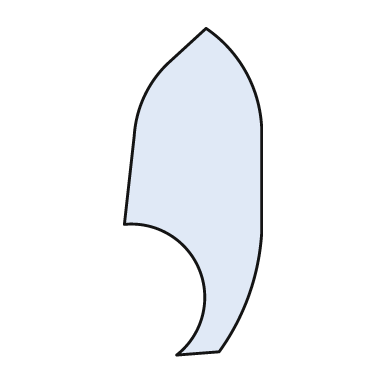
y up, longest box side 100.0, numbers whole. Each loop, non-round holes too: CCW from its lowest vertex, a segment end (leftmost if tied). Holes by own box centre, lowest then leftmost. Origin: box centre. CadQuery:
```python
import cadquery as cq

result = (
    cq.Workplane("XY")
    .moveTo(-5.0, -50.0)
    .lineTo(8.0, -49.0)
    .threePointArc((17.0, -32.0), (21.0, -13.0))
    .lineTo(21.0, 20.0)
    .threePointArc((16.0, 37.0), (4.0, 50.0))
    .lineTo(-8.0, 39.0)
    .threePointArc((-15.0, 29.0), (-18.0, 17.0))
    .lineTo(-21.0, -10.0)
    .threePointArc((2.0, -24.0), (-5.0, -50.0))
    .close()
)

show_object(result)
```